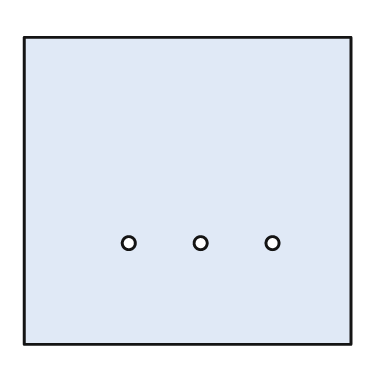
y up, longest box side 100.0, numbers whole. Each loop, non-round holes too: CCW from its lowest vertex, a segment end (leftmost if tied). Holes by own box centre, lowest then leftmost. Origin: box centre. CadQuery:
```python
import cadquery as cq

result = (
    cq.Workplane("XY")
    .moveTo(-50.0, -47.0)
    .lineTo(50.0, -47.0)
    .lineTo(50.0, 47.0)
    .lineTo(-50.0, 47.0)
    .close()
    .moveTo(-18.0, -16.0)
    .circle(2.0)
    .moveTo(4.0, -16.0)
    .circle(2.0)
    .moveTo(26.0, -16.0)
    .circle(2.0)
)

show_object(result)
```